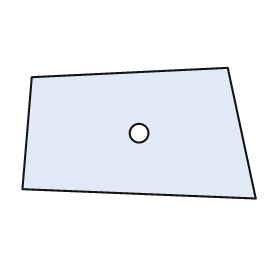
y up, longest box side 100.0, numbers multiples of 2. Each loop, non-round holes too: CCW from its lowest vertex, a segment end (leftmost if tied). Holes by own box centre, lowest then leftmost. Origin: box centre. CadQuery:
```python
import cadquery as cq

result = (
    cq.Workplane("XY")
    .moveTo(50.0, -28.0)
    .lineTo(38.0, 28.0)
    .lineTo(-46.0, 24.0)
    .lineTo(-50.0, -24.0)
    .close()
    .moveTo(0.0, 0.0)
    .circle(4.0)
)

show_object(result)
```